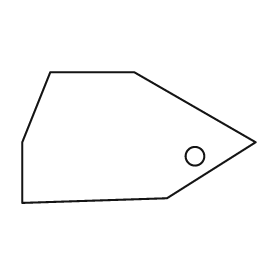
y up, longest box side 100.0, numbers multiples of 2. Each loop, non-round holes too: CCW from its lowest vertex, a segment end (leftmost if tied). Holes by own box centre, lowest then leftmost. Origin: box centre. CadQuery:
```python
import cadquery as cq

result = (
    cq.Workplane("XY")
    .moveTo(-50.0, -28.0)
    .lineTo(12.0, -26.0)
    .lineTo(50.0, -2.0)
    .lineTo(-2.0, 28.0)
    .lineTo(-38.0, 28.0)
    .lineTo(-50.0, -2.0)
    .close()
    .moveTo(24.0, -8.0)
    .circle(4.0)
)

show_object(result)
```